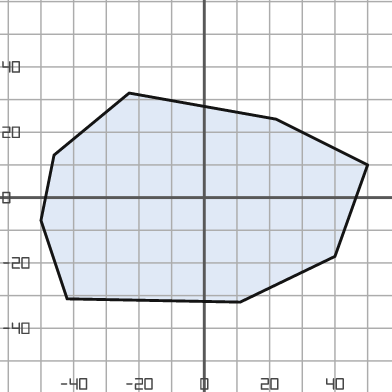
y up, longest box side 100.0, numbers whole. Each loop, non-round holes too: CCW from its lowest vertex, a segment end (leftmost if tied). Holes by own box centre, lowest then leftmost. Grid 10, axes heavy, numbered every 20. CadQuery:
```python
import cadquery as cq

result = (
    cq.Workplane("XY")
    .moveTo(11.0, -32.0)
    .lineTo(40.0, -18.0)
    .lineTo(50.0, 10.0)
    .lineTo(22.0, 24.0)
    .lineTo(-23.0, 32.0)
    .lineTo(-46.0, 13.0)
    .lineTo(-50.0, -7.0)
    .lineTo(-42.0, -31.0)
    .close()
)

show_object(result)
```